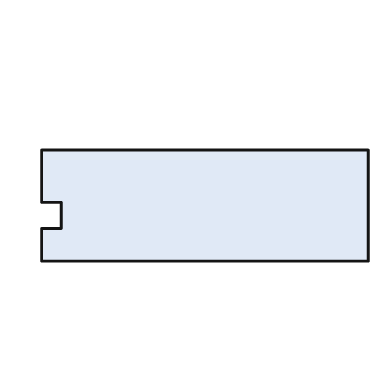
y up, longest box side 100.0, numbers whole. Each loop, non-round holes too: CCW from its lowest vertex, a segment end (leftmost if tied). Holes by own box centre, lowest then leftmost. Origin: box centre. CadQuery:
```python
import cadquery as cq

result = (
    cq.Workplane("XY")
    .moveTo(-50.0, -17.0)
    .lineTo(50.0, -17.0)
    .lineTo(50.0, 17.0)
    .lineTo(-50.0, 17.0)
    .lineTo(-50.0, 1.0)
    .lineTo(-44.0, 1.0)
    .lineTo(-44.0, -7.0)
    .lineTo(-50.0, -7.0)
    .close()
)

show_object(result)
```